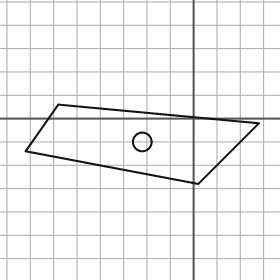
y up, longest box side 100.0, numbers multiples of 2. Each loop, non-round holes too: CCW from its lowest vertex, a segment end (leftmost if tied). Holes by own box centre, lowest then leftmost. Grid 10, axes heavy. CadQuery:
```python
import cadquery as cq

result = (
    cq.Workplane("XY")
    .moveTo(2.0, -28.0)
    .lineTo(28.0, -2.0)
    .lineTo(-58.0, 6.0)
    .lineTo(-72.0, -14.0)
    .close()
    .moveTo(-22.0, -10.0)
    .circle(4.0)
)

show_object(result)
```